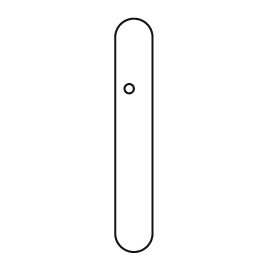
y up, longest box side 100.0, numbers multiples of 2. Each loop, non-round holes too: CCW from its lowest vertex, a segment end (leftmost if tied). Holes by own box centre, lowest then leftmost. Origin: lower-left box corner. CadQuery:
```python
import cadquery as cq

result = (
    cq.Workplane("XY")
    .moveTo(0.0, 8.0)
    .threePointArc((8.0, 0.0), (16.0, 8.0))
    .lineTo(16.0, 92.0)
    .threePointArc((8.0, 100.0), (0.0, 92.0))
    .close()
    .moveTo(6.0, 70.0)
    .circle(2.0)
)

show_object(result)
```